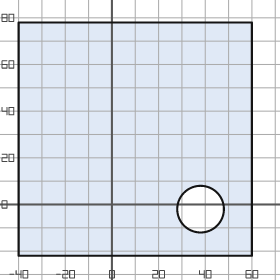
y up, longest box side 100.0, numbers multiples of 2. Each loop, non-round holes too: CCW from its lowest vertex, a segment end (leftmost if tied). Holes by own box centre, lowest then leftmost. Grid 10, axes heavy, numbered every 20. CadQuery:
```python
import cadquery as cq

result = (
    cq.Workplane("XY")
    .moveTo(-40.0, -22.0)
    .lineTo(60.0, -22.0)
    .lineTo(60.0, 78.0)
    .lineTo(-40.0, 78.0)
    .close()
    .moveTo(38.0, -2.0)
    .circle(10.0)
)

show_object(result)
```